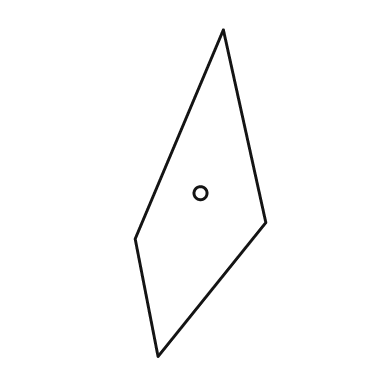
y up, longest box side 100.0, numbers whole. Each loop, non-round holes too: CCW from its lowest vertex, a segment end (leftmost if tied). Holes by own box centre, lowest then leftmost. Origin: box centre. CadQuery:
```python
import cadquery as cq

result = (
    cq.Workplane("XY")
    .moveTo(-13.0, -50.0)
    .lineTo(20.0, -9.0)
    .lineTo(7.0, 50.0)
    .lineTo(-20.0, -14.0)
    .close()
    .moveTo(0.0, 0.0)
    .circle(2.0)
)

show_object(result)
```